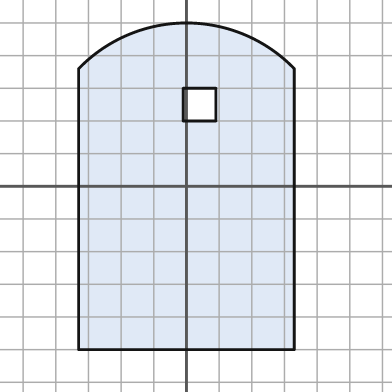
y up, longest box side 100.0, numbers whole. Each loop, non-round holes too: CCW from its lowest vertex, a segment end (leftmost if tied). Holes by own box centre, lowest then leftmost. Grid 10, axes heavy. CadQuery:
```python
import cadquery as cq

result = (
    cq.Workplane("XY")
    .moveTo(-33.0, -50.0)
    .lineTo(33.0, -50.0)
    .lineTo(33.0, 36.0)
    .threePointArc((0.0, 50.0), (-33.0, 36.0))
    .close()
    .moveTo(-1.0, 20.0)
    .lineTo(9.0, 20.0)
    .lineTo(9.0, 30.0)
    .lineTo(-1.0, 30.0)
    .close()
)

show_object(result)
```